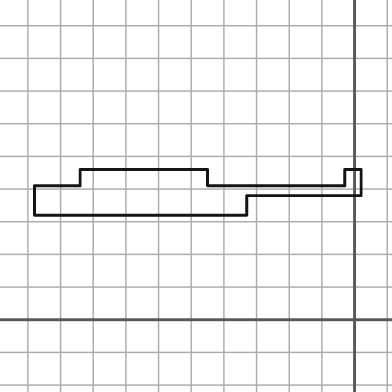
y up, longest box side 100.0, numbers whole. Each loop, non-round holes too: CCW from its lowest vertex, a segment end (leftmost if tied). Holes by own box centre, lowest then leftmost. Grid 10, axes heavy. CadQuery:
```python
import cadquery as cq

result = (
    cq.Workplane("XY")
    .moveTo(-98.0, 32.0)
    .lineTo(-33.0, 32.0)
    .lineTo(-33.0, 38.0)
    .lineTo(2.0, 38.0)
    .lineTo(2.0, 46.0)
    .lineTo(-3.0, 46.0)
    .lineTo(-3.0, 41.0)
    .lineTo(-45.0, 41.0)
    .lineTo(-45.0, 46.0)
    .lineTo(-84.0, 46.0)
    .lineTo(-84.0, 41.0)
    .lineTo(-98.0, 41.0)
    .close()
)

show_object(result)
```